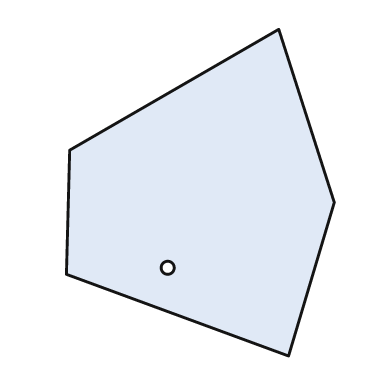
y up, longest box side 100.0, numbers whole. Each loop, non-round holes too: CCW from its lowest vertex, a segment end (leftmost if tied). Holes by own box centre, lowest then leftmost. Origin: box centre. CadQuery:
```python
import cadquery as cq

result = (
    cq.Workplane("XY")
    .moveTo(27.0, -50.0)
    .lineTo(41.0, -3.0)
    .lineTo(24.0, 50.0)
    .lineTo(-40.0, 13.0)
    .lineTo(-41.0, -25.0)
    .close()
    .moveTo(-10.0, -23.0)
    .circle(2.0)
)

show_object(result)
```